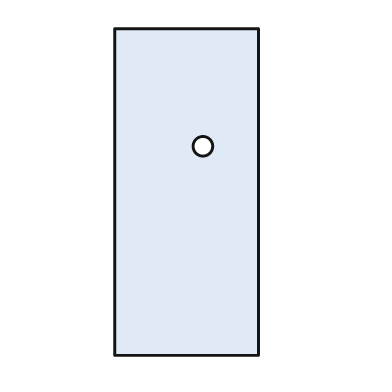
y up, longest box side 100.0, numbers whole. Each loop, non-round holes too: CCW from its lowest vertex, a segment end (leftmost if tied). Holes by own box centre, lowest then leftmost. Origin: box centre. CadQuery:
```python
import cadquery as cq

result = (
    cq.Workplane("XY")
    .moveTo(-22.0, -50.0)
    .lineTo(22.0, -50.0)
    .lineTo(22.0, 50.0)
    .lineTo(-22.0, 50.0)
    .close()
    .moveTo(5.0, 14.0)
    .circle(3.0)
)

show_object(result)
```